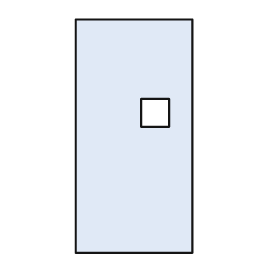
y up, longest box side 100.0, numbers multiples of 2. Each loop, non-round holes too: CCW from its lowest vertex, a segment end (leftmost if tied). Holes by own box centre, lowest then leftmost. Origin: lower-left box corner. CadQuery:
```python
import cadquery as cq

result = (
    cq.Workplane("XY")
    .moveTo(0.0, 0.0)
    .lineTo(50.0, 0.0)
    .lineTo(50.0, 100.0)
    .lineTo(0.0, 100.0)
    .close()
    .moveTo(28.0, 54.0)
    .lineTo(40.0, 54.0)
    .lineTo(40.0, 66.0)
    .lineTo(28.0, 66.0)
    .close()
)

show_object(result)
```